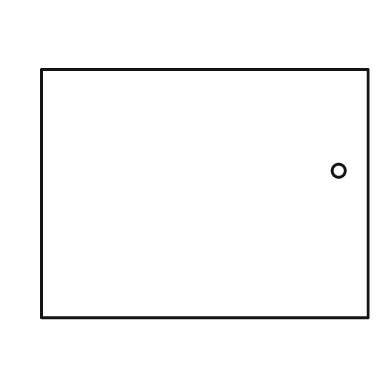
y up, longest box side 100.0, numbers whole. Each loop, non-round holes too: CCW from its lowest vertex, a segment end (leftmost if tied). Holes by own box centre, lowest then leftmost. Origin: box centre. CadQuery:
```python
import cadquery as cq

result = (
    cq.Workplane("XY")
    .moveTo(-50.0, -38.0)
    .lineTo(50.0, -38.0)
    .lineTo(50.0, 38.0)
    .lineTo(-50.0, 38.0)
    .close()
    .moveTo(41.0, 7.0)
    .circle(2.0)
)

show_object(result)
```